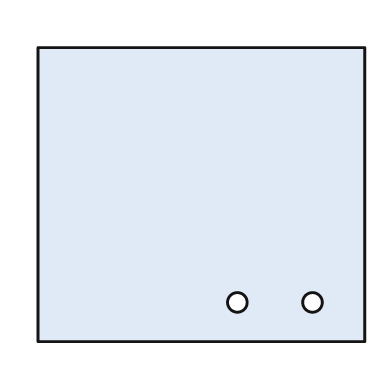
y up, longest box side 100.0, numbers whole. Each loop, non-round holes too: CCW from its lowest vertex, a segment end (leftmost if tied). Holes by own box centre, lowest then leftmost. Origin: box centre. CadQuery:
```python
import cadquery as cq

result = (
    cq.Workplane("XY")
    .moveTo(-50.0, -45.0)
    .lineTo(50.0, -45.0)
    .lineTo(50.0, 45.0)
    .lineTo(-50.0, 45.0)
    .close()
    .moveTo(11.0, -33.0)
    .circle(3.0)
    .moveTo(34.0, -33.0)
    .circle(3.0)
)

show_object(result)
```